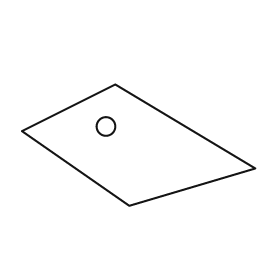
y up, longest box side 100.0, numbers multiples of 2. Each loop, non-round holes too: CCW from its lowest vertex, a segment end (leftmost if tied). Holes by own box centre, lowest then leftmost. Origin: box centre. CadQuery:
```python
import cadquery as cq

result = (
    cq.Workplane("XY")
    .moveTo(-4.0, -26.0)
    .lineTo(50.0, -10.0)
    .lineTo(-10.0, 26.0)
    .lineTo(-50.0, 6.0)
    .close()
    .moveTo(-14.0, 8.0)
    .circle(4.0)
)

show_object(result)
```